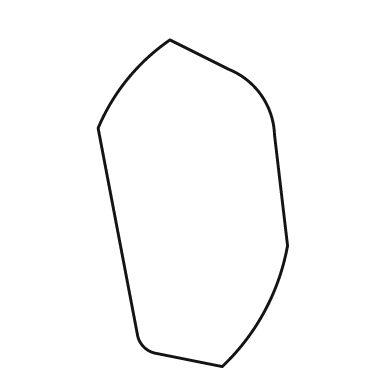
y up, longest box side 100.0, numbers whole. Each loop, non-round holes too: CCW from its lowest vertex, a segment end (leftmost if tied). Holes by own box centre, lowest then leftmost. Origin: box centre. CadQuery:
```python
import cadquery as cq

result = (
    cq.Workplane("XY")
    .moveTo(9.0, -50.0)
    .threePointArc((22.0, -33.0), (29.0, -13.0))
    .lineTo(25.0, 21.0)
    .threePointArc((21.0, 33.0), (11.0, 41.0))
    .lineTo(-7.0, 50.0)
    .threePointArc((-20.0, 38.0), (-29.0, 23.0))
    .lineTo(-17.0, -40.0)
    .threePointArc((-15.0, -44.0), (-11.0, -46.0))
    .close()
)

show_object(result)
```